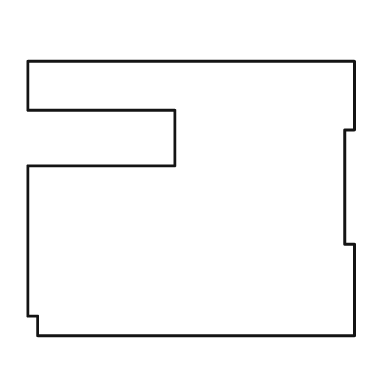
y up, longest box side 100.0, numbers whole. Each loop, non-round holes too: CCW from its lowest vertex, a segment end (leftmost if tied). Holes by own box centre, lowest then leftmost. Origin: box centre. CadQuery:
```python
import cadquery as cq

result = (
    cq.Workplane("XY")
    .moveTo(-47.0, -42.0)
    .lineTo(50.0, -42.0)
    .lineTo(50.0, -14.0)
    .lineTo(47.0, -14.0)
    .lineTo(47.0, 21.0)
    .lineTo(50.0, 21.0)
    .lineTo(50.0, 42.0)
    .lineTo(-50.0, 42.0)
    .lineTo(-50.0, 27.0)
    .lineTo(-5.0, 27.0)
    .lineTo(-5.0, 10.0)
    .lineTo(-50.0, 10.0)
    .lineTo(-50.0, -36.0)
    .lineTo(-47.0, -36.0)
    .close()
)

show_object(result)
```